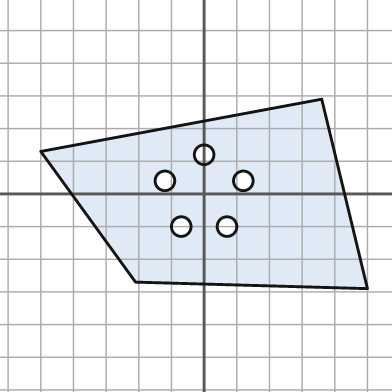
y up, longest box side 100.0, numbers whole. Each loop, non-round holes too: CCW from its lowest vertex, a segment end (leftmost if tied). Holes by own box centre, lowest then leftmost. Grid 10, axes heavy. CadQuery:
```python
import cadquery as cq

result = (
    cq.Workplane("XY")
    .moveTo(50.0, -29.0)
    .lineTo(36.0, 29.0)
    .lineTo(-50.0, 13.0)
    .lineTo(-21.0, -27.0)
    .close()
    .moveTo(-7.0, -10.0)
    .circle(3.0)
    .moveTo(7.0, -10.0)
    .circle(3.0)
    .moveTo(-12.0, 4.0)
    .circle(3.0)
    .moveTo(12.0, 4.0)
    .circle(3.0)
    .moveTo(0.0, 12.0)
    .circle(3.0)
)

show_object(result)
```